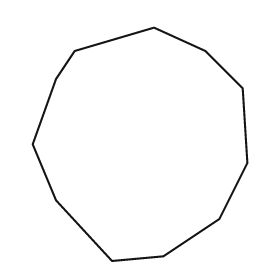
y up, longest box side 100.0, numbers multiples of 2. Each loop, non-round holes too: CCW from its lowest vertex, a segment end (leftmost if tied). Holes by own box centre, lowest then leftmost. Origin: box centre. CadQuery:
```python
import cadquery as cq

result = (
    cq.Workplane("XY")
    .moveTo(-12.0, -50.0)
    .lineTo(10.0, -48.0)
    .lineTo(34.0, -32.0)
    .lineTo(46.0, -8.0)
    .lineTo(44.0, 24.0)
    .lineTo(28.0, 40.0)
    .lineTo(6.0, 50.0)
    .lineTo(-28.0, 40.0)
    .lineTo(-36.0, 28.0)
    .lineTo(-46.0, 0.0)
    .lineTo(-36.0, -24.0)
    .close()
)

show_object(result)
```